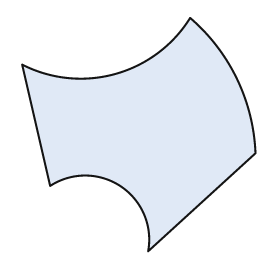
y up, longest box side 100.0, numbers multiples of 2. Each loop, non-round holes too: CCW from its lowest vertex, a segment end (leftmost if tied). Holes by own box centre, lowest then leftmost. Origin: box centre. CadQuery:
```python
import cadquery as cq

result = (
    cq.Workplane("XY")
    .moveTo(4.0, -50.0)
    .lineTo(50.0, -8.0)
    .threePointArc((42.0, 24.0), (22.0, 50.0))
    .threePointArc((-10.0, 26.0), (-50.0, 30.0))
    .lineTo(-38.0, -22.0)
    .threePointArc((-8.0, -22.0), (4.0, -50.0))
    .close()
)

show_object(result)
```